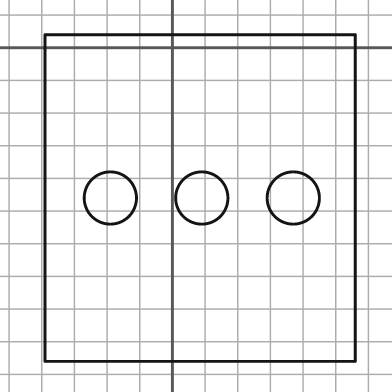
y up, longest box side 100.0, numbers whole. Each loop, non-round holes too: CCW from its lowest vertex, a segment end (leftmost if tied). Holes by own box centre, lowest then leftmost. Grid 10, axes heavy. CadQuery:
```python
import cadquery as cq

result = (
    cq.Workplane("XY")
    .moveTo(-39.0, -96.0)
    .lineTo(56.0, -96.0)
    .lineTo(56.0, 4.0)
    .lineTo(-39.0, 4.0)
    .close()
    .moveTo(-19.0, -46.0)
    .circle(8.0)
    .moveTo(9.0, -46.0)
    .circle(8.0)
    .moveTo(37.0, -46.0)
    .circle(8.0)
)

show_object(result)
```